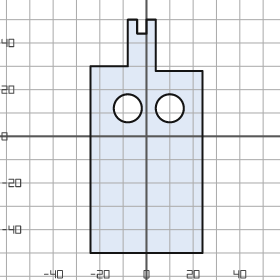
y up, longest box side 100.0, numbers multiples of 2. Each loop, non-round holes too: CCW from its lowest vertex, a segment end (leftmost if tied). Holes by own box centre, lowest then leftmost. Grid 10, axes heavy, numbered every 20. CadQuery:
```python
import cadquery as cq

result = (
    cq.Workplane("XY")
    .moveTo(-24.0, -50.0)
    .lineTo(24.0, -50.0)
    .lineTo(24.0, 28.0)
    .lineTo(4.0, 28.0)
    .lineTo(4.0, 50.0)
    .lineTo(0.0, 50.0)
    .lineTo(0.0, 44.0)
    .lineTo(-4.0, 44.0)
    .lineTo(-4.0, 50.0)
    .lineTo(-8.0, 50.0)
    .lineTo(-8.0, 30.0)
    .lineTo(-24.0, 30.0)
    .close()
    .moveTo(-8.0, 12.0)
    .circle(6.0)
    .moveTo(10.0, 12.0)
    .circle(6.0)
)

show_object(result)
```